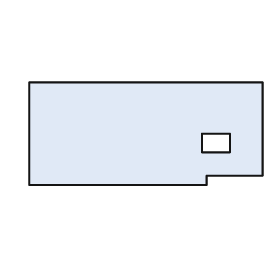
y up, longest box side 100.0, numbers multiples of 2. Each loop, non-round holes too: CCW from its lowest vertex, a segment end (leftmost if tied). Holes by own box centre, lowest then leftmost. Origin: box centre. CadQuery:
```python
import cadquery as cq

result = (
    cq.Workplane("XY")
    .moveTo(-50.0, -22.0)
    .lineTo(26.0, -22.0)
    .lineTo(26.0, -18.0)
    .lineTo(50.0, -18.0)
    .lineTo(50.0, 22.0)
    .lineTo(-50.0, 22.0)
    .close()
    .moveTo(24.0, -8.0)
    .lineTo(36.0, -8.0)
    .lineTo(36.0, 0.0)
    .lineTo(24.0, 0.0)
    .close()
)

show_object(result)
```